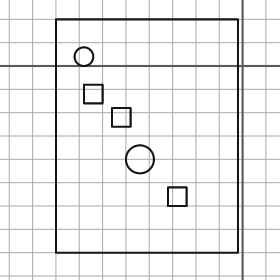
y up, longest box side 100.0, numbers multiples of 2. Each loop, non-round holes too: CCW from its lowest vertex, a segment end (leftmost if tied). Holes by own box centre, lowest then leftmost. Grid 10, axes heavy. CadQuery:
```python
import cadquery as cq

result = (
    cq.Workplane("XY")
    .moveTo(-80.0, -80.0)
    .lineTo(-2.0, -80.0)
    .lineTo(-2.0, 20.0)
    .lineTo(-80.0, 20.0)
    .close()
    .moveTo(-32.0, -60.0)
    .lineTo(-24.0, -60.0)
    .lineTo(-24.0, -52.0)
    .lineTo(-32.0, -52.0)
    .close()
    .moveTo(-44.0, -40.0)
    .circle(6.0)
    .moveTo(-56.0, -26.0)
    .lineTo(-48.0, -26.0)
    .lineTo(-48.0, -18.0)
    .lineTo(-56.0, -18.0)
    .close()
    .moveTo(-68.0, -16.0)
    .lineTo(-60.0, -16.0)
    .lineTo(-60.0, -8.0)
    .lineTo(-68.0, -8.0)
    .close()
    .moveTo(-68.0, 4.0)
    .circle(4.0)
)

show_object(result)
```